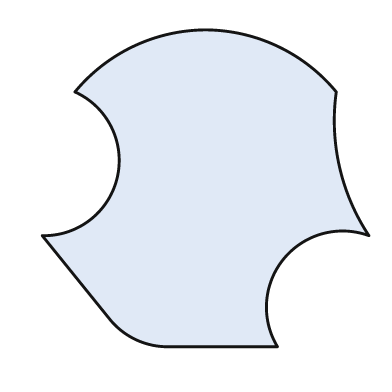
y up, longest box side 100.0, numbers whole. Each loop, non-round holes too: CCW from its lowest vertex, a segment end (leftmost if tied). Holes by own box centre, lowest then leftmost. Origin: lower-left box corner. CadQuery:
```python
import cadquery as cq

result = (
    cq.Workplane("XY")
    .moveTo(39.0, 0.0)
    .lineTo(72.0, 0.0)
    .threePointArc((74.0, 27.0), (100.0, 34.0))
    .threePointArc((91.0, 55.0), (90.0, 78.0))
    .threePointArc((72.0, 92.0), (50.0, 97.0))
    .threePointArc((28.0, 92.0), (10.0, 78.0))
    .threePointArc((23.0, 52.0), (0.0, 34.0))
    .lineTo(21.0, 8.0)
    .threePointArc((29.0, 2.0), (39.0, 0.0))
    .close()
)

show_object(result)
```